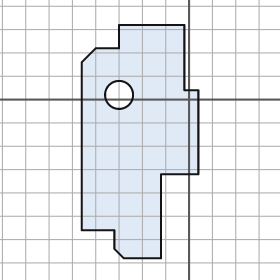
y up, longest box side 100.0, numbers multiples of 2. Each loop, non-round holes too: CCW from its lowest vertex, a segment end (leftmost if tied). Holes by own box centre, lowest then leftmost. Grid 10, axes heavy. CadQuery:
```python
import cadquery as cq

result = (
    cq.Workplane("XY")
    .moveTo(-28.0, -68.0)
    .lineTo(-12.0, -68.0)
    .lineTo(-12.0, -32.0)
    .lineTo(4.0, -32.0)
    .lineTo(4.0, 4.0)
    .lineTo(-2.0, 4.0)
    .lineTo(-2.0, 32.0)
    .lineTo(-30.0, 32.0)
    .lineTo(-30.0, 22.0)
    .lineTo(-40.0, 22.0)
    .lineTo(-46.0, 16.0)
    .lineTo(-46.0, -56.0)
    .lineTo(-32.0, -56.0)
    .lineTo(-32.0, -64.0)
    .close()
    .moveTo(-30.0, 2.0)
    .circle(6.0)
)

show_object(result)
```